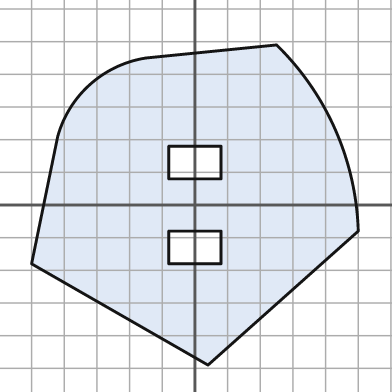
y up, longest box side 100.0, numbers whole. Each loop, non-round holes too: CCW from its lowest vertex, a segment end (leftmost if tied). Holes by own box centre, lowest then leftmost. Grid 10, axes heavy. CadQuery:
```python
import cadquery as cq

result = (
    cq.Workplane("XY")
    .moveTo(4.0, -49.0)
    .lineTo(50.0, -8.0)
    .threePointArc((43.0, 23.0), (25.0, 49.0))
    .lineTo(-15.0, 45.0)
    .threePointArc((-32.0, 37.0), (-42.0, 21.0))
    .lineTo(-50.0, -18.0)
    .close()
    .moveTo(-8.0, -18.0)
    .lineTo(8.0, -18.0)
    .lineTo(8.0, -8.0)
    .lineTo(-8.0, -8.0)
    .close()
    .moveTo(-8.0, 8.0)
    .lineTo(8.0, 8.0)
    .lineTo(8.0, 18.0)
    .lineTo(-8.0, 18.0)
    .close()
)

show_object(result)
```